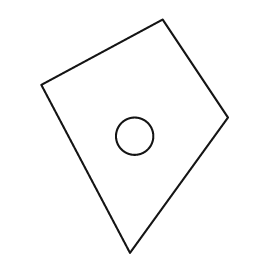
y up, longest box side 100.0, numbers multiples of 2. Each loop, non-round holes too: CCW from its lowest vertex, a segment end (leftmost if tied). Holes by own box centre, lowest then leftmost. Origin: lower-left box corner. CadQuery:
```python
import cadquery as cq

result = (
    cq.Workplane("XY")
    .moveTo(38.0, 0.0)
    .lineTo(80.0, 58.0)
    .lineTo(52.0, 100.0)
    .lineTo(0.0, 72.0)
    .close()
    .moveTo(40.0, 50.0)
    .circle(8.0)
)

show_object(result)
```